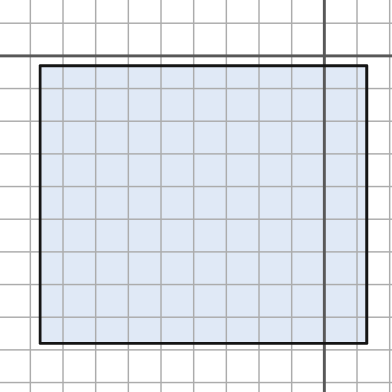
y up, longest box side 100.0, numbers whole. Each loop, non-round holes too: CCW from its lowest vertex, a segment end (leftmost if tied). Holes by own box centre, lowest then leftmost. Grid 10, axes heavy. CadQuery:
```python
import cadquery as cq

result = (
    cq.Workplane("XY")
    .moveTo(-87.0, -88.0)
    .lineTo(13.0, -88.0)
    .lineTo(13.0, -3.0)
    .lineTo(-87.0, -3.0)
    .close()
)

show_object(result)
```